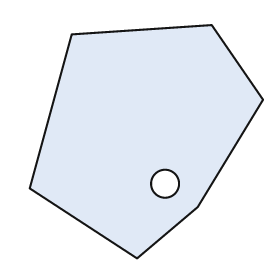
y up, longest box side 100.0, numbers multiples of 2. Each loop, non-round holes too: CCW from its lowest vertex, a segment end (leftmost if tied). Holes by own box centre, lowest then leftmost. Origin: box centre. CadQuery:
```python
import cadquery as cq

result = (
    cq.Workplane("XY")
    .moveTo(-4.0, -50.0)
    .lineTo(22.0, -28.0)
    .lineTo(50.0, 18.0)
    .lineTo(28.0, 50.0)
    .lineTo(-32.0, 46.0)
    .lineTo(-50.0, -20.0)
    .close()
    .moveTo(8.0, -18.0)
    .circle(6.0)
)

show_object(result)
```